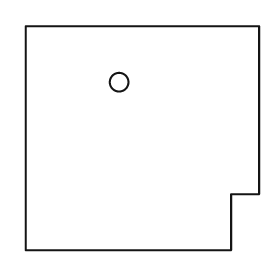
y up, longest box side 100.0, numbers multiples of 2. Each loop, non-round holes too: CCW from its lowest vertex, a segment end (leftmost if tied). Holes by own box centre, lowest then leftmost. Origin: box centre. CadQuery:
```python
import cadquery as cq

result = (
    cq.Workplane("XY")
    .moveTo(-50.0, -48.0)
    .lineTo(38.0, -48.0)
    .lineTo(38.0, -24.0)
    .lineTo(50.0, -24.0)
    .lineTo(50.0, 48.0)
    .lineTo(-50.0, 48.0)
    .close()
    .moveTo(-10.0, 24.0)
    .circle(4.0)
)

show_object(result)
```